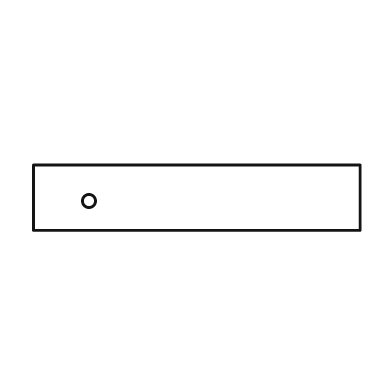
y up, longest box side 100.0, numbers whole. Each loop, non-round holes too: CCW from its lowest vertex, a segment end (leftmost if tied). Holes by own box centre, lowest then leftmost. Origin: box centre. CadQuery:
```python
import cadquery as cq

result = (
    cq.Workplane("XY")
    .moveTo(-50.0, -10.0)
    .lineTo(50.0, -10.0)
    .lineTo(50.0, 10.0)
    .lineTo(-50.0, 10.0)
    .close()
    .moveTo(-33.0, -1.0)
    .circle(2.0)
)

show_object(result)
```